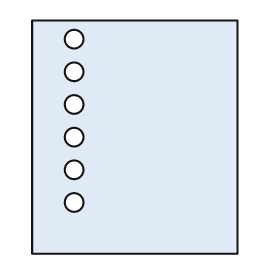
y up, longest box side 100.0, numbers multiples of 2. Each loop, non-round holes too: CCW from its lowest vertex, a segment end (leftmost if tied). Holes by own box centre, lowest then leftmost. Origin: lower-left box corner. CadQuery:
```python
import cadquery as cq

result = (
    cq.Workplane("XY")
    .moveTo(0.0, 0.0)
    .lineTo(88.0, 0.0)
    .lineTo(88.0, 100.0)
    .lineTo(0.0, 100.0)
    .close()
    .moveTo(18.0, 22.0)
    .circle(4.0)
    .moveTo(18.0, 36.0)
    .circle(4.0)
    .moveTo(18.0, 50.0)
    .circle(4.0)
    .moveTo(18.0, 64.0)
    .circle(4.0)
    .moveTo(18.0, 78.0)
    .circle(4.0)
    .moveTo(18.0, 92.0)
    .circle(4.0)
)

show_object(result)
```